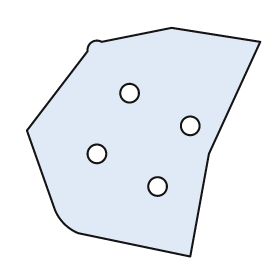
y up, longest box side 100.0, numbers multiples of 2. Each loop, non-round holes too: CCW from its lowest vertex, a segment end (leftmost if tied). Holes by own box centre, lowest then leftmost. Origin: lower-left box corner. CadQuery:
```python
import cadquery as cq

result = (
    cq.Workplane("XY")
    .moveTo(70.0, 0.0)
    .lineTo(78.0, 44.0)
    .lineTo(100.0, 92.0)
    .lineTo(62.0, 98.0)
    .lineTo(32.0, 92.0)
    .threePointArc((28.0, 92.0), (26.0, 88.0))
    .lineTo(0.0, 54.0)
    .lineTo(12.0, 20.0)
    .threePointArc((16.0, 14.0), (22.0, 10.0))
    .close()
    .moveTo(56.0, 30.0)
    .circle(4.0)
    .moveTo(30.0, 44.0)
    .circle(4.0)
    .moveTo(70.0, 56.0)
    .circle(4.0)
    .moveTo(44.0, 70.0)
    .circle(4.0)
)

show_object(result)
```